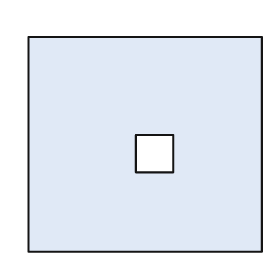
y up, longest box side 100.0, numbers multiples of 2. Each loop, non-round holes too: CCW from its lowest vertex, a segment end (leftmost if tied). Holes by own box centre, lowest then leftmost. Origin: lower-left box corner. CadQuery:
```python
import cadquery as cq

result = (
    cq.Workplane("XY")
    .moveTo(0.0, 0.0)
    .lineTo(100.0, 0.0)
    .lineTo(100.0, 92.0)
    .lineTo(0.0, 92.0)
    .close()
    .moveTo(46.0, 34.0)
    .lineTo(62.0, 34.0)
    .lineTo(62.0, 50.0)
    .lineTo(46.0, 50.0)
    .close()
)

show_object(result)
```